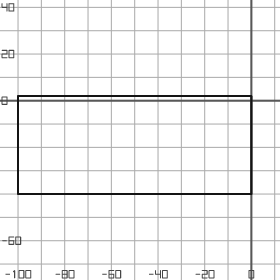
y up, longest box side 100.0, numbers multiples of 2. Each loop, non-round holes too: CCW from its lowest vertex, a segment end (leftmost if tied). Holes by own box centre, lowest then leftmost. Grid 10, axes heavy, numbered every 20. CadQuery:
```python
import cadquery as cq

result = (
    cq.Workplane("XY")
    .moveTo(-100.0, -40.0)
    .lineTo(0.0, -40.0)
    .lineTo(0.0, 2.0)
    .lineTo(-100.0, 2.0)
    .close()
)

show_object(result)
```